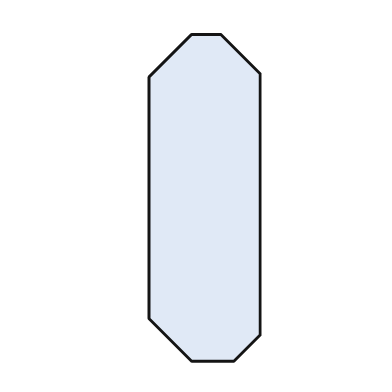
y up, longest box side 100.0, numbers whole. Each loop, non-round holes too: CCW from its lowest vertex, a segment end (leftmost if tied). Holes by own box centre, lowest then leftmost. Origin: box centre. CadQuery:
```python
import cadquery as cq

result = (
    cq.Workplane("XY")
    .moveTo(-4.0, -50.0)
    .lineTo(9.0, -50.0)
    .lineTo(17.0, -42.0)
    .lineTo(17.0, 38.0)
    .lineTo(5.0, 50.0)
    .lineTo(-4.0, 50.0)
    .lineTo(-17.0, 37.0)
    .lineTo(-17.0, -37.0)
    .close()
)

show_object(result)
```